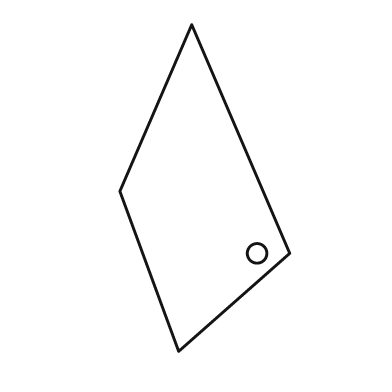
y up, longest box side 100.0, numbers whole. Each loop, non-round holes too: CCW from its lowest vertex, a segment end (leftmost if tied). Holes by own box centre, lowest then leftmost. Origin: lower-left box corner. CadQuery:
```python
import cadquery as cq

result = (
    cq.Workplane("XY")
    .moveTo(18.0, 0.0)
    .lineTo(52.0, 30.0)
    .lineTo(22.0, 100.0)
    .lineTo(0.0, 49.0)
    .close()
    .moveTo(42.0, 30.0)
    .circle(3.0)
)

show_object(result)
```